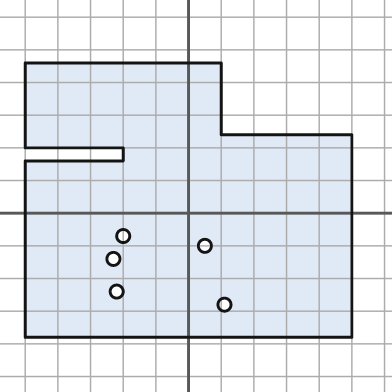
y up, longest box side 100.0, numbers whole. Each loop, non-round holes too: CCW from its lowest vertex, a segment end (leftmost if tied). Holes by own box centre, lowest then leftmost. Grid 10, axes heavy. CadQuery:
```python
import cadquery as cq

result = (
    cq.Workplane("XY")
    .moveTo(-50.0, -38.0)
    .lineTo(50.0, -38.0)
    .lineTo(50.0, 24.0)
    .lineTo(10.0, 24.0)
    .lineTo(10.0, 46.0)
    .lineTo(-50.0, 46.0)
    .lineTo(-50.0, 20.0)
    .lineTo(-20.0, 20.0)
    .lineTo(-20.0, 16.0)
    .lineTo(-50.0, 16.0)
    .close()
    .moveTo(11.0, -28.0)
    .circle(2.0)
    .moveTo(-22.0, -24.0)
    .circle(2.0)
    .moveTo(-23.0, -14.0)
    .circle(2.0)
    .moveTo(5.0, -10.0)
    .circle(2.0)
    .moveTo(-20.0, -7.0)
    .circle(2.0)
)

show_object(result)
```